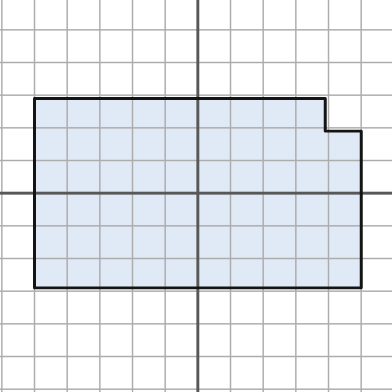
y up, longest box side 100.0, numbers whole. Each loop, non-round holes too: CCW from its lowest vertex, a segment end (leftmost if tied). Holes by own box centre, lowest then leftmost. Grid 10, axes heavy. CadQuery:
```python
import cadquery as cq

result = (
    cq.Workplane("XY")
    .moveTo(-50.0, -29.0)
    .lineTo(50.0, -29.0)
    .lineTo(50.0, 19.0)
    .lineTo(39.0, 19.0)
    .lineTo(39.0, 29.0)
    .lineTo(-50.0, 29.0)
    .close()
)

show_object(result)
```